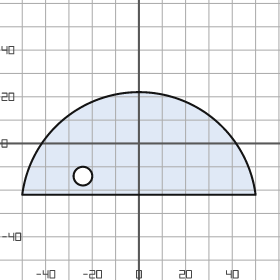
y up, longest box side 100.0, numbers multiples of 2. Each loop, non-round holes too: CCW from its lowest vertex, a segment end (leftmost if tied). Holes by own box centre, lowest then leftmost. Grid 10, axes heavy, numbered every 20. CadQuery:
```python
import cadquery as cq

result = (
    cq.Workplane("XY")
    .moveTo(-50.0, -22.0)
    .lineTo(50.0, -22.0)
    .threePointArc((0.0, 22.0), (-50.0, -22.0))
    .close()
    .moveTo(-24.0, -14.0)
    .circle(4.0)
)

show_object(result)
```